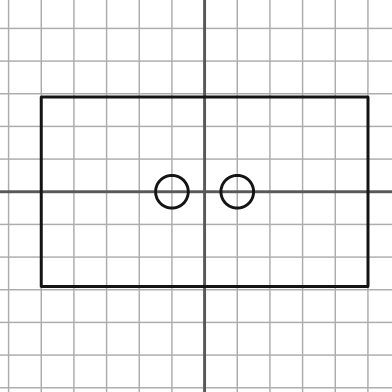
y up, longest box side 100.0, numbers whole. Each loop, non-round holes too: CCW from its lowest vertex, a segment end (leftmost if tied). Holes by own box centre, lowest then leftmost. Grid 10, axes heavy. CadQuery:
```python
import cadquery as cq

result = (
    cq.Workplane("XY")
    .moveTo(-50.0, -29.0)
    .lineTo(50.0, -29.0)
    .lineTo(50.0, 29.0)
    .lineTo(-50.0, 29.0)
    .close()
    .moveTo(-10.0, 0.0)
    .circle(5.0)
    .moveTo(10.0, 0.0)
    .circle(5.0)
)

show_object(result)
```